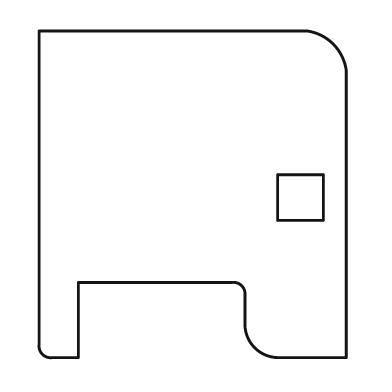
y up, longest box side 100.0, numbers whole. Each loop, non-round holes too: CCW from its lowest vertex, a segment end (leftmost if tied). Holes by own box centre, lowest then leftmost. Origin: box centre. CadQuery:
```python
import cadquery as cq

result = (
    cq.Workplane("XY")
    .moveTo(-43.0, -50.0)
    .lineTo(-35.0, -50.0)
    .lineTo(-35.0, -27.0)
    .lineTo(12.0, -27.0)
    .threePointArc((15.0, -28.0), (16.0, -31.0))
    .lineTo(16.0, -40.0)
    .threePointArc((19.0, -47.0), (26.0, -50.0))
    .lineTo(47.0, -50.0)
    .lineTo(47.0, 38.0)
    .threePointArc((43.0, 46.0), (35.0, 50.0))
    .lineTo(-47.0, 50.0)
    .lineTo(-47.0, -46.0)
    .threePointArc((-46.0, -49.0), (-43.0, -50.0))
    .close()
    .moveTo(26.0, -8.0)
    .lineTo(40.0, -8.0)
    .lineTo(40.0, 6.0)
    .lineTo(26.0, 6.0)
    .close()
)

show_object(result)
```